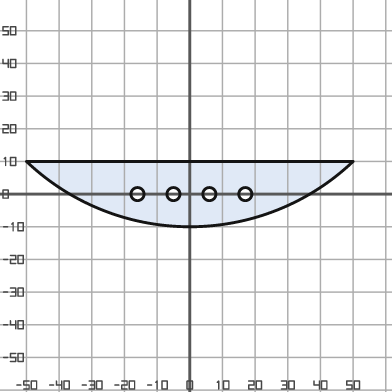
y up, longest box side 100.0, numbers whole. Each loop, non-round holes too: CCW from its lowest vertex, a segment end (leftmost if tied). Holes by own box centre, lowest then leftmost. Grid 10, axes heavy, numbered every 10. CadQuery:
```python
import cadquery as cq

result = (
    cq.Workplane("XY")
    .moveTo(-50.0, 10.0)
    .threePointArc((0.0, -10.0), (50.0, 10.0))
    .close()
    .moveTo(-16.0, 0.0)
    .circle(2.0)
    .moveTo(-5.0, 0.0)
    .circle(2.0)
    .moveTo(6.0, 0.0)
    .circle(2.0)
    .moveTo(17.0, 0.0)
    .circle(2.0)
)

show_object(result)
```